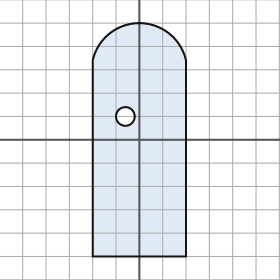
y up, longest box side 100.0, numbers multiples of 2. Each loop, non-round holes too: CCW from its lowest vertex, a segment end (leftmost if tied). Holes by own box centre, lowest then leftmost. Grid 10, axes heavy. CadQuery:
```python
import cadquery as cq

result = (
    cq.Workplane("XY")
    .moveTo(-20.0, -50.0)
    .lineTo(20.0, -50.0)
    .lineTo(20.0, 34.0)
    .threePointArc((0.0, 50.0), (-20.0, 34.0))
    .close()
    .moveTo(-6.0, 10.0)
    .circle(4.0)
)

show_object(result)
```